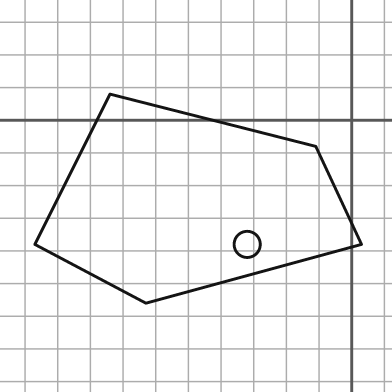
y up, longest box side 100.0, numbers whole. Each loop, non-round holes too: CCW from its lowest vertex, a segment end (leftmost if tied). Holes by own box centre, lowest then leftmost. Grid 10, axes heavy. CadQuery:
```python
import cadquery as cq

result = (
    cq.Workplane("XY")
    .moveTo(-63.0, -56.0)
    .lineTo(3.0, -38.0)
    .lineTo(-11.0, -8.0)
    .lineTo(-74.0, 8.0)
    .lineTo(-97.0, -38.0)
    .close()
    .moveTo(-32.0, -38.0)
    .circle(4.0)
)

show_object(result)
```